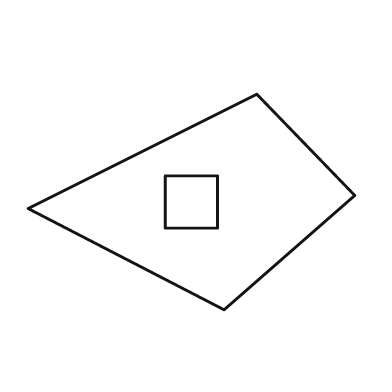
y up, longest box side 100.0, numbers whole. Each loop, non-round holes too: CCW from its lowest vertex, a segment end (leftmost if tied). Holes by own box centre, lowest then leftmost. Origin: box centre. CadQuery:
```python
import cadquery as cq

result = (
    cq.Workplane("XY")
    .moveTo(10.0, -33.0)
    .lineTo(50.0, 2.0)
    .lineTo(20.0, 33.0)
    .lineTo(-50.0, -2.0)
    .close()
    .moveTo(-8.0, -8.0)
    .lineTo(8.0, -8.0)
    .lineTo(8.0, 8.0)
    .lineTo(-8.0, 8.0)
    .close()
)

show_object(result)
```